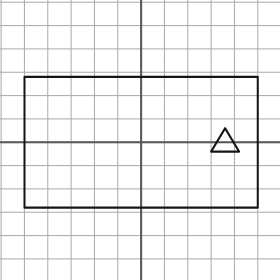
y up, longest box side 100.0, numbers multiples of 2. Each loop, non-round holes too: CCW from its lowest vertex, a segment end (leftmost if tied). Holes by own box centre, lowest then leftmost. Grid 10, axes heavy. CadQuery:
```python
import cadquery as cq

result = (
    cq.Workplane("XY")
    .moveTo(-50.0, -28.0)
    .lineTo(50.0, -28.0)
    .lineTo(50.0, 28.0)
    .lineTo(-50.0, 28.0)
    .close()
    .moveTo(30.0, -4.0)
    .lineTo(42.0, -4.0)
    .lineTo(36.0, 6.0)
    .close()
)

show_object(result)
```